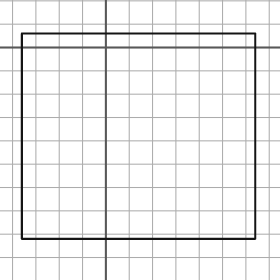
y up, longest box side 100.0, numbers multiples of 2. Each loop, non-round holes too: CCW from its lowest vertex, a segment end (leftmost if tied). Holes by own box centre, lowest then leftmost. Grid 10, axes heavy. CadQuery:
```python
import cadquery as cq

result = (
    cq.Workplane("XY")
    .moveTo(-36.0, -82.0)
    .lineTo(64.0, -82.0)
    .lineTo(64.0, 6.0)
    .lineTo(-36.0, 6.0)
    .close()
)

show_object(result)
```